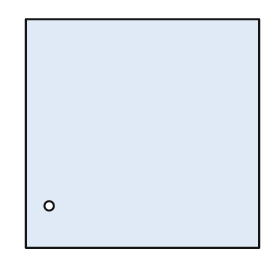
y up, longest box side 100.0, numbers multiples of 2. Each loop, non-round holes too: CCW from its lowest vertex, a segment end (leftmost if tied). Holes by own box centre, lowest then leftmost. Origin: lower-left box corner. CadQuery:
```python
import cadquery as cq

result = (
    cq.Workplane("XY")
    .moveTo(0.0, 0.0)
    .lineTo(100.0, 0.0)
    .lineTo(100.0, 98.0)
    .lineTo(0.0, 98.0)
    .close()
    .moveTo(10.0, 18.0)
    .circle(2.0)
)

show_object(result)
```